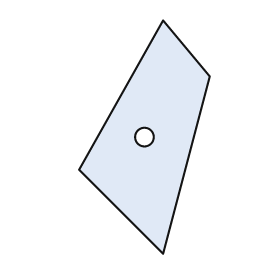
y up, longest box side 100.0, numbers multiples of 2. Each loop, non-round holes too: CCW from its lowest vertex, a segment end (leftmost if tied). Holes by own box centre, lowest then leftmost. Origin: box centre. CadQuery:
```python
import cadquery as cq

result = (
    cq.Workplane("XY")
    .moveTo(8.0, -50.0)
    .lineTo(28.0, 26.0)
    .lineTo(8.0, 50.0)
    .lineTo(-28.0, -14.0)
    .close()
    .moveTo(0.0, 0.0)
    .circle(4.0)
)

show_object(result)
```